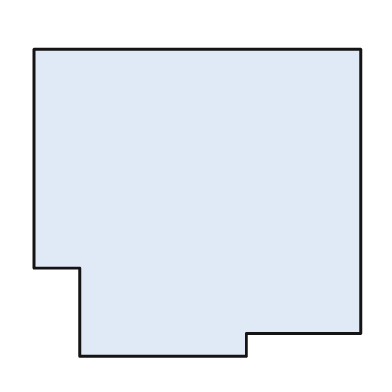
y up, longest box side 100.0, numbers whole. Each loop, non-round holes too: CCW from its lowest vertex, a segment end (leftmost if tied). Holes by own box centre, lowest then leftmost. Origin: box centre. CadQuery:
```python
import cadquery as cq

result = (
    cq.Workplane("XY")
    .moveTo(-36.0, -47.0)
    .lineTo(15.0, -47.0)
    .lineTo(15.0, -40.0)
    .lineTo(50.0, -40.0)
    .lineTo(50.0, 47.0)
    .lineTo(-50.0, 47.0)
    .lineTo(-50.0, -20.0)
    .lineTo(-36.0, -20.0)
    .close()
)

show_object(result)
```